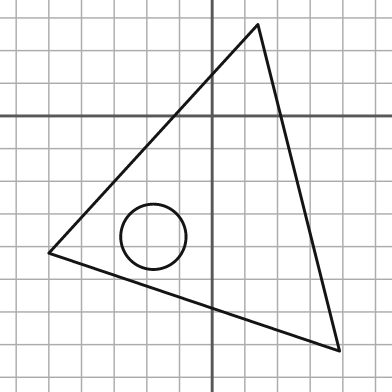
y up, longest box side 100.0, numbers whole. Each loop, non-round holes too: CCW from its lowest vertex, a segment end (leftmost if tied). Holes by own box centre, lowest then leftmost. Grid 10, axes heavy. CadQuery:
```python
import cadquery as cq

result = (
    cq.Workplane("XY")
    .moveTo(39.0, -72.0)
    .lineTo(14.0, 28.0)
    .lineTo(-50.0, -42.0)
    .close()
    .moveTo(-18.0, -37.0)
    .circle(10.0)
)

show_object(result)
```